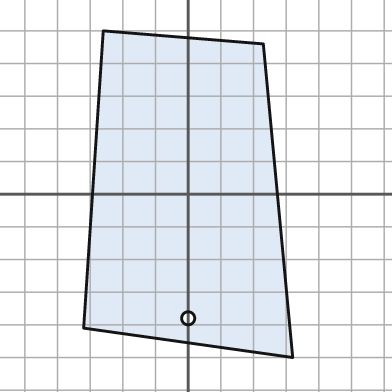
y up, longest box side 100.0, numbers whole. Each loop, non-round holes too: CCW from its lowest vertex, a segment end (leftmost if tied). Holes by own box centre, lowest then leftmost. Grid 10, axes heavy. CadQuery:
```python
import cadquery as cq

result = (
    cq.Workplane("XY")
    .moveTo(32.0, -50.0)
    .lineTo(23.0, 46.0)
    .lineTo(-26.0, 50.0)
    .lineTo(-32.0, -41.0)
    .close()
    .moveTo(0.0, -38.0)
    .circle(2.0)
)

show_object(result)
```